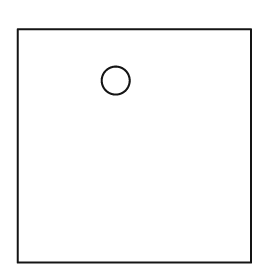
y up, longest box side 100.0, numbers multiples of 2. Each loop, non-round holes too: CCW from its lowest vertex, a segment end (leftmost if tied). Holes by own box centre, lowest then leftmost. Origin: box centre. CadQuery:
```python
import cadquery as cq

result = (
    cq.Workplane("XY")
    .moveTo(-50.0, -50.0)
    .lineTo(50.0, -50.0)
    .lineTo(50.0, 50.0)
    .lineTo(-50.0, 50.0)
    .close()
    .moveTo(-8.0, 28.0)
    .circle(6.0)
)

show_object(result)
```